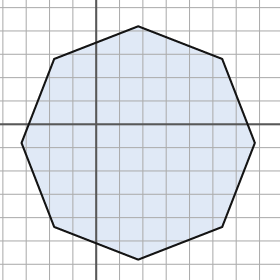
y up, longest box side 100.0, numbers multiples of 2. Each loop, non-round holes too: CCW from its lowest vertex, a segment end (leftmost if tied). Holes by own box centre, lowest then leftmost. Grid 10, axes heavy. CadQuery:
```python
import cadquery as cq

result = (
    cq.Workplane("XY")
    .moveTo(18.0, -58.0)
    .lineTo(54.0, -44.0)
    .lineTo(68.0, -8.0)
    .lineTo(54.0, 28.0)
    .lineTo(18.0, 42.0)
    .lineTo(-18.0, 28.0)
    .lineTo(-32.0, -8.0)
    .lineTo(-18.0, -44.0)
    .close()
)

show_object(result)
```